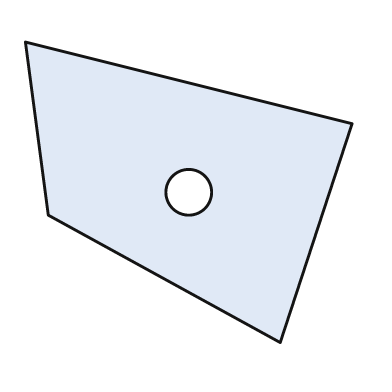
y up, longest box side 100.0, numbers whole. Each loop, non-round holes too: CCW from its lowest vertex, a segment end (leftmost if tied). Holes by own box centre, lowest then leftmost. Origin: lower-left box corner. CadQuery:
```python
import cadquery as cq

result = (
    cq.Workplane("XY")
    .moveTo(78.0, 0.0)
    .lineTo(100.0, 67.0)
    .lineTo(0.0, 92.0)
    .lineTo(7.0, 39.0)
    .close()
    .moveTo(50.0, 46.0)
    .circle(7.0)
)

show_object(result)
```